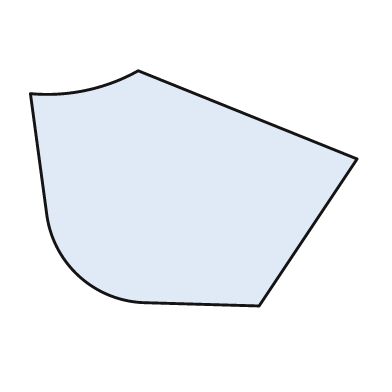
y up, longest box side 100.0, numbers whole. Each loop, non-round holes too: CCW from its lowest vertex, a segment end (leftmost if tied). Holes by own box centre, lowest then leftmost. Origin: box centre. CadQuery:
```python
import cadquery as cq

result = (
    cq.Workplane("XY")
    .moveTo(20.0, -36.0)
    .lineTo(50.0, 9.0)
    .lineTo(-17.0, 36.0)
    .threePointArc((-33.0, 30.0), (-50.0, 29.0))
    .lineTo(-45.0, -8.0)
    .threePointArc((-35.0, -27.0), (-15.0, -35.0))
    .close()
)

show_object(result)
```